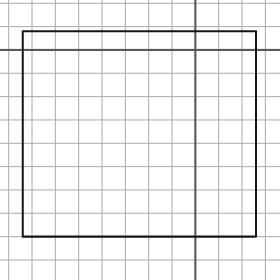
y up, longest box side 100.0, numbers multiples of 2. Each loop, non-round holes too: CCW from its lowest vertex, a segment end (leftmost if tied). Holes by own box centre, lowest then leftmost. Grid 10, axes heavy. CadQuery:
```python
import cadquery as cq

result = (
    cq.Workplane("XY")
    .moveTo(-74.0, -80.0)
    .lineTo(26.0, -80.0)
    .lineTo(26.0, 8.0)
    .lineTo(-74.0, 8.0)
    .close()
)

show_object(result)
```